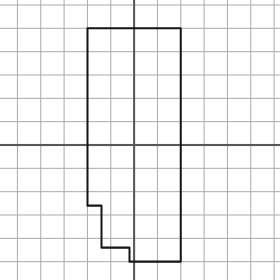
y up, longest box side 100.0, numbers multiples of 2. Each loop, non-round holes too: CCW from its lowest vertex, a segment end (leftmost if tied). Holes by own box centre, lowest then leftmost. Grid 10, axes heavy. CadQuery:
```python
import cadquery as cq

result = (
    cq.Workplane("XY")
    .moveTo(-2.0, -50.0)
    .lineTo(20.0, -50.0)
    .lineTo(20.0, 50.0)
    .lineTo(-20.0, 50.0)
    .lineTo(-20.0, -26.0)
    .lineTo(-14.0, -26.0)
    .lineTo(-14.0, -44.0)
    .lineTo(-2.0, -44.0)
    .close()
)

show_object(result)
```